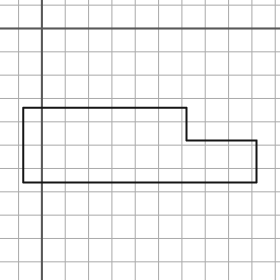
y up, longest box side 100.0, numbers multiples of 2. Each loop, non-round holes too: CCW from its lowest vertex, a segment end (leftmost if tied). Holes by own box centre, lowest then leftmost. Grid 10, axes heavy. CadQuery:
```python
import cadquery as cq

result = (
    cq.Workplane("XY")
    .moveTo(-8.0, -66.0)
    .lineTo(92.0, -66.0)
    .lineTo(92.0, -48.0)
    .lineTo(62.0, -48.0)
    .lineTo(62.0, -34.0)
    .lineTo(-8.0, -34.0)
    .close()
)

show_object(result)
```